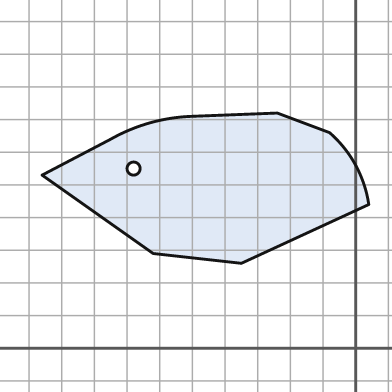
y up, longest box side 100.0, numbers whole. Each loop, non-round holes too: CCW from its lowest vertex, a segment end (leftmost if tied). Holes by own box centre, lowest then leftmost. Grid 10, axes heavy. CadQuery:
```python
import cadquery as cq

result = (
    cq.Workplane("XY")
    .moveTo(-35.0, 26.0)
    .lineTo(4.0, 44.0)
    .threePointArc((0.0, 56.0), (-8.0, 66.0))
    .lineTo(-24.0, 72.0)
    .lineTo(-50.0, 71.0)
    .threePointArc((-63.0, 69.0), (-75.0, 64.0))
    .lineTo(-96.0, 53.0)
    .lineTo(-62.0, 29.0)
    .close()
    .moveTo(-68.0, 55.0)
    .circle(2.0)
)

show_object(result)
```